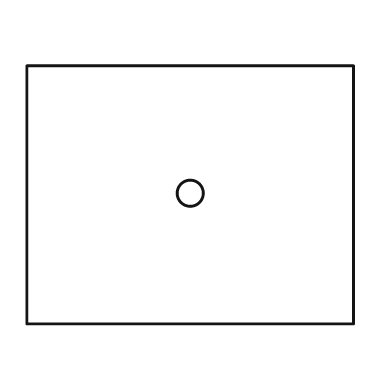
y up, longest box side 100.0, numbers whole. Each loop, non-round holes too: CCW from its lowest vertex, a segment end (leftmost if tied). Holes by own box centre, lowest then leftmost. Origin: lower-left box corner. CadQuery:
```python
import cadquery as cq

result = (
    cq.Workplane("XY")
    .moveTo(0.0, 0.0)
    .lineTo(100.0, 0.0)
    .lineTo(100.0, 79.0)
    .lineTo(0.0, 79.0)
    .close()
    .moveTo(50.0, 40.0)
    .circle(4.0)
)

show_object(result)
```